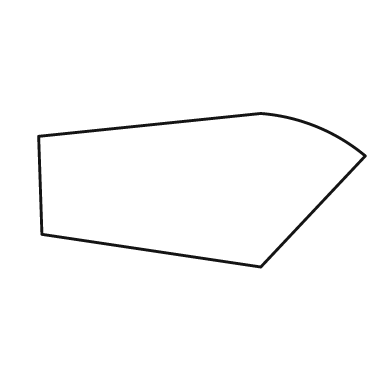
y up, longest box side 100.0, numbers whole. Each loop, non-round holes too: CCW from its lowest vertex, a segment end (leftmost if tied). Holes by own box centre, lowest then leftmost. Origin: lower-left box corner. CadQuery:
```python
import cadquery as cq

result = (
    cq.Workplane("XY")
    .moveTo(68.0, 0.0)
    .lineTo(100.0, 34.0)
    .threePointArc((85.0, 43.0), (68.0, 47.0))
    .lineTo(0.0, 40.0)
    .lineTo(1.0, 10.0)
    .close()
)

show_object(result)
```